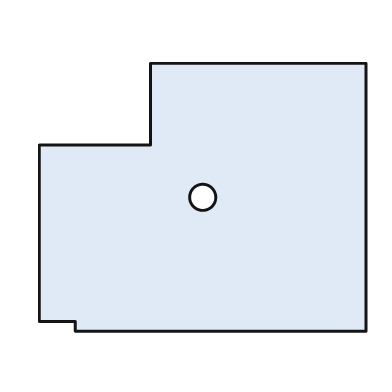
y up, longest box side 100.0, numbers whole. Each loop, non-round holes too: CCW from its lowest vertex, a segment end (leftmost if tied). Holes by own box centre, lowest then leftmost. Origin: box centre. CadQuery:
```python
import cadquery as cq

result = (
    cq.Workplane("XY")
    .moveTo(-39.0, -41.0)
    .lineTo(50.0, -41.0)
    .lineTo(50.0, 41.0)
    .lineTo(-16.0, 41.0)
    .lineTo(-16.0, 16.0)
    .lineTo(-50.0, 16.0)
    .lineTo(-50.0, -38.0)
    .lineTo(-39.0, -38.0)
    .close()
    .moveTo(0.0, 0.0)
    .circle(4.0)
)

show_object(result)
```